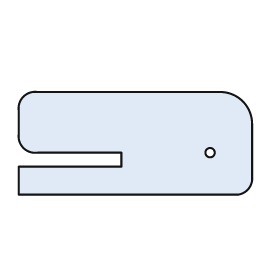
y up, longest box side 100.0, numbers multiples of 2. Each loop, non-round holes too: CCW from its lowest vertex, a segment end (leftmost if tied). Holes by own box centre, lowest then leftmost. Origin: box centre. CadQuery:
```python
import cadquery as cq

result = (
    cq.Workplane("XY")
    .moveTo(-50.0, -22.0)
    .lineTo(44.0, -22.0)
    .threePointArc((48.0, -20.0), (50.0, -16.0))
    .lineTo(50.0, 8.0)
    .threePointArc((46.0, 18.0), (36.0, 22.0))
    .lineTo(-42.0, 22.0)
    .threePointArc((-48.0, 20.0), (-50.0, 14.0))
    .lineTo(-50.0, 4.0)
    .threePointArc((-48.0, -2.0), (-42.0, -4.0))
    .lineTo(-6.0, -4.0)
    .lineTo(-6.0, -10.0)
    .lineTo(-50.0, -10.0)
    .close()
    .moveTo(32.0, -4.0)
    .circle(2.0)
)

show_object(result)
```